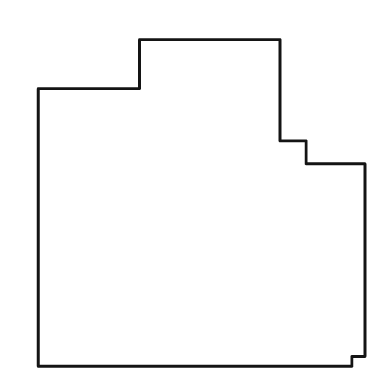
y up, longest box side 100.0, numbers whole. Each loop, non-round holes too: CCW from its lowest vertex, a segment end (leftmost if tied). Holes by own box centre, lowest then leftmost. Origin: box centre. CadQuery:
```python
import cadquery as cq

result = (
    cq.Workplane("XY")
    .moveTo(-50.0, -50.0)
    .lineTo(46.0, -50.0)
    .lineTo(46.0, -47.0)
    .lineTo(50.0, -47.0)
    .lineTo(50.0, 12.0)
    .lineTo(32.0, 12.0)
    .lineTo(32.0, 19.0)
    .lineTo(24.0, 19.0)
    .lineTo(24.0, 50.0)
    .lineTo(-19.0, 50.0)
    .lineTo(-19.0, 35.0)
    .lineTo(-50.0, 35.0)
    .close()
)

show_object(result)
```